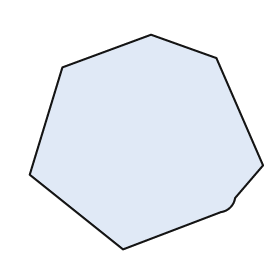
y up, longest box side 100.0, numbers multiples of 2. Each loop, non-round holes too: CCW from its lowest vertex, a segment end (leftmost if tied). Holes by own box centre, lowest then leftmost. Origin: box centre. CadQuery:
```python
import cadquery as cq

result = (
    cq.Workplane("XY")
    .moveTo(-10.0, -46.0)
    .lineTo(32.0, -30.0)
    .threePointArc((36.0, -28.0), (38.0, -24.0))
    .lineTo(50.0, -10.0)
    .lineTo(30.0, 36.0)
    .lineTo(2.0, 46.0)
    .lineTo(-36.0, 32.0)
    .lineTo(-50.0, -14.0)
    .close()
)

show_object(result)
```